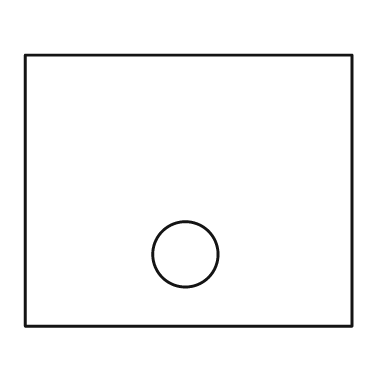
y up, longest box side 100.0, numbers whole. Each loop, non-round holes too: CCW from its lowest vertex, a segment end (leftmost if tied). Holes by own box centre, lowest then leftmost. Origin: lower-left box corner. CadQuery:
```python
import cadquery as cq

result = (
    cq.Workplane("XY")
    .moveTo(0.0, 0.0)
    .lineTo(100.0, 0.0)
    .lineTo(100.0, 83.0)
    .lineTo(0.0, 83.0)
    .close()
    .moveTo(49.0, 22.0)
    .circle(10.0)
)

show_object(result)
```